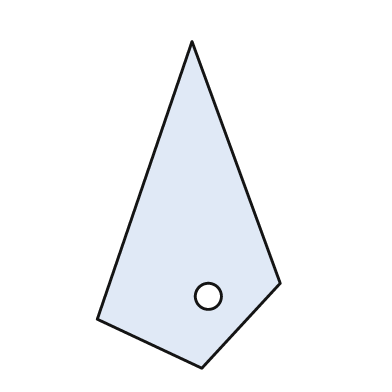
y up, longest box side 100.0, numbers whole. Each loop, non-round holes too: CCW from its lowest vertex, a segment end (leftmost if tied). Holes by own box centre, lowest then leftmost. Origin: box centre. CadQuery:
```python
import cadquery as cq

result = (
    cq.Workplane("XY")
    .moveTo(4.0, -50.0)
    .lineTo(28.0, -24.0)
    .lineTo(1.0, 50.0)
    .lineTo(-28.0, -35.0)
    .close()
    .moveTo(6.0, -28.0)
    .circle(4.0)
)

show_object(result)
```